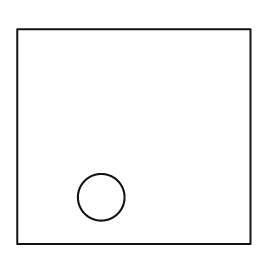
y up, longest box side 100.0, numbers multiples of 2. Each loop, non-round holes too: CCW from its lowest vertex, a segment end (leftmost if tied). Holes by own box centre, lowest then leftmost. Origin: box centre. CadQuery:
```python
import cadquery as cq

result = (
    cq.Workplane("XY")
    .moveTo(-50.0, -46.0)
    .lineTo(50.0, -46.0)
    .lineTo(50.0, 46.0)
    .lineTo(-50.0, 46.0)
    .close()
    .moveTo(-14.0, -26.0)
    .circle(10.0)
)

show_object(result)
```